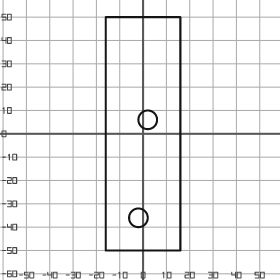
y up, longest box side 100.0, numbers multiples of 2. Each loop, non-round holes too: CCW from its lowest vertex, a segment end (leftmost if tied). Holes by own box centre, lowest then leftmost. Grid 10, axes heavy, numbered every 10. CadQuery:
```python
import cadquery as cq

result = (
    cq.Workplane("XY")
    .moveTo(-16.0, -50.0)
    .lineTo(16.0, -50.0)
    .lineTo(16.0, 50.0)
    .lineTo(-16.0, 50.0)
    .close()
    .moveTo(-2.0, -36.0)
    .circle(4.0)
    .moveTo(2.0, 6.0)
    .circle(4.0)
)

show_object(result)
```